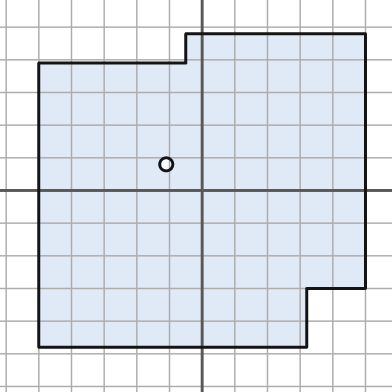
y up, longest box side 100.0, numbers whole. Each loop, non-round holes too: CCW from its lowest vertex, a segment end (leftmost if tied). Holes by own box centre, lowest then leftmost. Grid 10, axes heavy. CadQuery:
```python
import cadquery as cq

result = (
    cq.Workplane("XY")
    .moveTo(-50.0, -48.0)
    .lineTo(32.0, -48.0)
    .lineTo(32.0, -30.0)
    .lineTo(50.0, -30.0)
    .lineTo(50.0, 48.0)
    .lineTo(-5.0, 48.0)
    .lineTo(-5.0, 39.0)
    .lineTo(-50.0, 39.0)
    .close()
    .moveTo(-11.0, 8.0)
    .circle(2.0)
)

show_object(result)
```